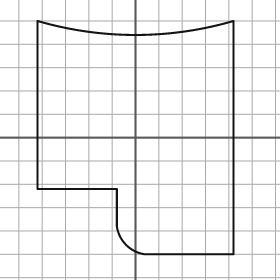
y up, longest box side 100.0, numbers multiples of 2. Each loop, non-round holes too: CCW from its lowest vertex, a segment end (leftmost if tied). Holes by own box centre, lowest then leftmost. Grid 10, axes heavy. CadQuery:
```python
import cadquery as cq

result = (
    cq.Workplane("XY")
    .moveTo(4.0, -50.0)
    .lineTo(42.0, -50.0)
    .lineTo(42.0, 50.0)
    .threePointArc((0.0, 44.0), (-42.0, 50.0))
    .lineTo(-42.0, -22.0)
    .lineTo(-8.0, -22.0)
    .lineTo(-8.0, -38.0)
    .threePointArc((-4.0, -46.0), (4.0, -50.0))
    .close()
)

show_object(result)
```